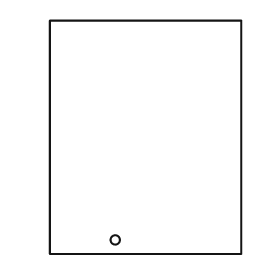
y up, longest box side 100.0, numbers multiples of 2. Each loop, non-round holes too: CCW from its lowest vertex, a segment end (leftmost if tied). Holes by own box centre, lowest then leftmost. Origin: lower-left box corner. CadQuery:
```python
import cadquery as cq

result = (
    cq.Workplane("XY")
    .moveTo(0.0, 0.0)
    .lineTo(82.0, 0.0)
    .lineTo(82.0, 100.0)
    .lineTo(0.0, 100.0)
    .close()
    .moveTo(28.0, 6.0)
    .circle(2.0)
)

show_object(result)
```